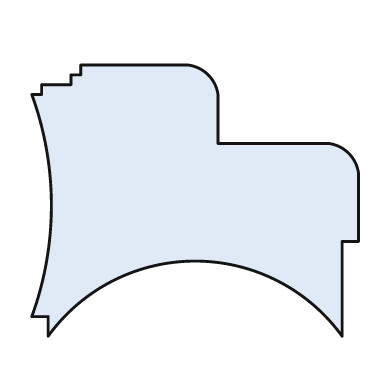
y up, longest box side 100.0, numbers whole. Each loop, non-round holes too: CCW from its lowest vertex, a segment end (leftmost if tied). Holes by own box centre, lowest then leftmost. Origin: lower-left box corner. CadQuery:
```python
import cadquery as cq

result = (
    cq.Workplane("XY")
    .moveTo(5.0, 0.0)
    .threePointArc((50.0, 23.0), (95.0, 0.0))
    .lineTo(95.0, 29.0)
    .lineTo(100.0, 29.0)
    .lineTo(100.0, 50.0)
    .threePointArc((97.0, 56.0), (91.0, 59.0))
    .lineTo(57.0, 59.0)
    .lineTo(57.0, 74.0)
    .threePointArc((54.0, 80.0), (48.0, 83.0))
    .lineTo(15.0, 83.0)
    .lineTo(15.0, 80.0)
    .lineTo(12.0, 80.0)
    .lineTo(12.0, 77.0)
    .lineTo(3.0, 77.0)
    .lineTo(3.0, 74.0)
    .lineTo(0.0, 74.0)
    .threePointArc((6.0, 40.0), (0.0, 6.0))
    .lineTo(5.0, 6.0)
    .close()
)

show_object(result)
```